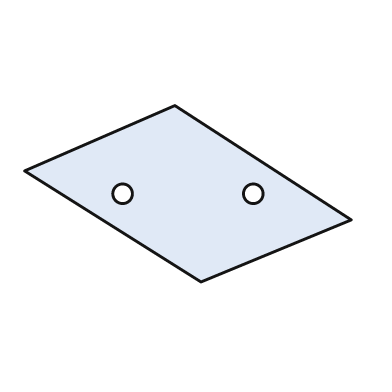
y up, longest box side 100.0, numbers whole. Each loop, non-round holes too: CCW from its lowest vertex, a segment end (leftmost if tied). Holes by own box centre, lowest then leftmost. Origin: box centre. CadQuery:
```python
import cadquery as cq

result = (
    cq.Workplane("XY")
    .moveTo(4.0, -27.0)
    .lineTo(50.0, -8.0)
    .lineTo(-4.0, 27.0)
    .lineTo(-50.0, 7.0)
    .close()
    .moveTo(-20.0, 0.0)
    .circle(3.0)
    .moveTo(20.0, 0.0)
    .circle(3.0)
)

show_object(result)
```